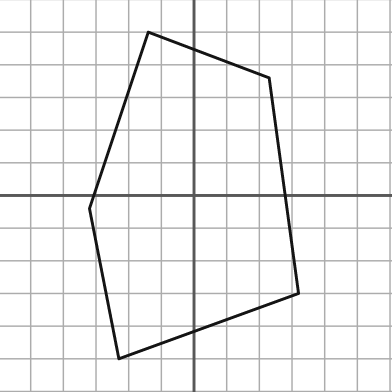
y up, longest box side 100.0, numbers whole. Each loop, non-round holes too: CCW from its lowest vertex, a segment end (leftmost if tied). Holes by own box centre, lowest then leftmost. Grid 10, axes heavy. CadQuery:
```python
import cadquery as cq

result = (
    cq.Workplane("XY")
    .moveTo(-23.0, -50.0)
    .lineTo(32.0, -30.0)
    .lineTo(23.0, 36.0)
    .lineTo(-14.0, 50.0)
    .lineTo(-32.0, -4.0)
    .close()
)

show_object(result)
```